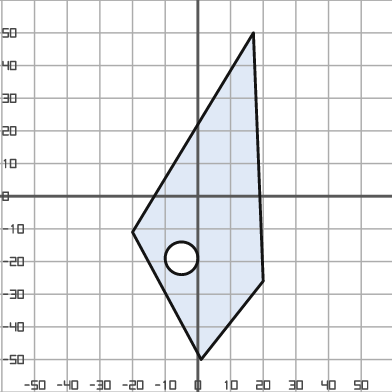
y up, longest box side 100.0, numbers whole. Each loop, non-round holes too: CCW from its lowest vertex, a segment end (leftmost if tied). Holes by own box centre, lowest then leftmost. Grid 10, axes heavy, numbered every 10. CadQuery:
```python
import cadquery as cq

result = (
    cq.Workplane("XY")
    .moveTo(1.0, -50.0)
    .lineTo(20.0, -26.0)
    .lineTo(17.0, 50.0)
    .lineTo(-20.0, -11.0)
    .close()
    .moveTo(-5.0, -19.0)
    .circle(5.0)
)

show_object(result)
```